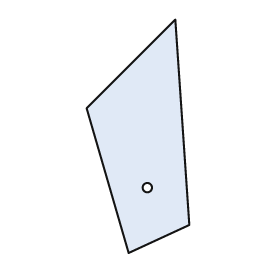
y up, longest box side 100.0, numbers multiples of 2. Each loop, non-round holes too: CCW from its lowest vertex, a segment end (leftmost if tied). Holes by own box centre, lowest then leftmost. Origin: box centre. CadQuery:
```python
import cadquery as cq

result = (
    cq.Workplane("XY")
    .moveTo(-4.0, -50.0)
    .lineTo(22.0, -38.0)
    .lineTo(16.0, 50.0)
    .lineTo(-22.0, 12.0)
    .close()
    .moveTo(4.0, -22.0)
    .circle(2.0)
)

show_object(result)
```